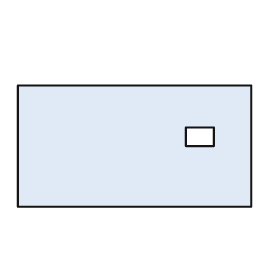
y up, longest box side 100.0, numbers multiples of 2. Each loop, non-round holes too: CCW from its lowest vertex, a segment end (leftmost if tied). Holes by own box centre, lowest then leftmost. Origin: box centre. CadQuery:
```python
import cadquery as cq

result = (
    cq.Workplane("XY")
    .moveTo(-50.0, -26.0)
    .lineTo(50.0, -26.0)
    .lineTo(50.0, 26.0)
    .lineTo(-50.0, 26.0)
    .close()
    .moveTo(22.0, 0.0)
    .lineTo(34.0, 0.0)
    .lineTo(34.0, 8.0)
    .lineTo(22.0, 8.0)
    .close()
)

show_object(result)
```